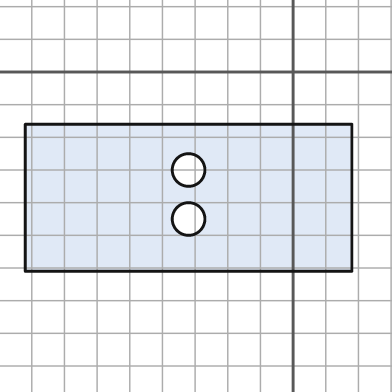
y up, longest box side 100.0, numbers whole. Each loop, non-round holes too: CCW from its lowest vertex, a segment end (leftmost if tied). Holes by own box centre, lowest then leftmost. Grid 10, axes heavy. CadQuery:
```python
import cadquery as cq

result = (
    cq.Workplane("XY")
    .moveTo(-82.0, -61.0)
    .lineTo(18.0, -61.0)
    .lineTo(18.0, -16.0)
    .lineTo(-82.0, -16.0)
    .close()
    .moveTo(-32.0, -45.0)
    .circle(5.0)
    .moveTo(-32.0, -30.0)
    .circle(5.0)
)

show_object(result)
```